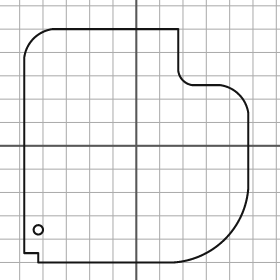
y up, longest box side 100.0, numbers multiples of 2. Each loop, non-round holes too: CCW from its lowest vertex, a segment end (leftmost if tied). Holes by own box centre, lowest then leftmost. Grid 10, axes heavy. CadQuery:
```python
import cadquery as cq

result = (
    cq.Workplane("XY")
    .moveTo(-42.0, -50.0)
    .lineTo(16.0, -50.0)
    .threePointArc((38.0, -40.0), (48.0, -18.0))
    .lineTo(48.0, 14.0)
    .threePointArc((44.0, 22.0), (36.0, 26.0))
    .lineTo(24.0, 26.0)
    .threePointArc((20.0, 28.0), (18.0, 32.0))
    .lineTo(18.0, 50.0)
    .lineTo(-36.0, 50.0)
    .threePointArc((-44.0, 46.0), (-48.0, 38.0))
    .lineTo(-48.0, -46.0)
    .lineTo(-42.0, -46.0)
    .close()
    .moveTo(-42.0, -36.0)
    .circle(2.0)
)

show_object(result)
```